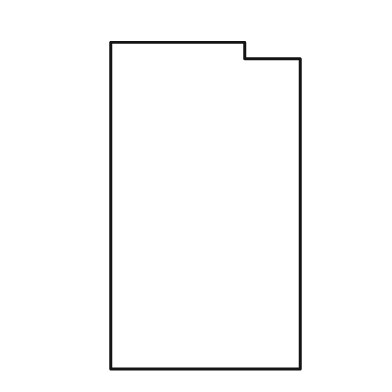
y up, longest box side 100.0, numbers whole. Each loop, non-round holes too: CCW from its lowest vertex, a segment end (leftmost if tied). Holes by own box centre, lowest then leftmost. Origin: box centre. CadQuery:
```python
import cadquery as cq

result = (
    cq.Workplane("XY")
    .moveTo(-29.0, -50.0)
    .lineTo(29.0, -50.0)
    .lineTo(29.0, 45.0)
    .lineTo(12.0, 45.0)
    .lineTo(12.0, 50.0)
    .lineTo(-29.0, 50.0)
    .close()
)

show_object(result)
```